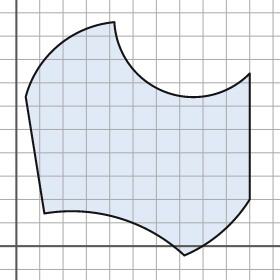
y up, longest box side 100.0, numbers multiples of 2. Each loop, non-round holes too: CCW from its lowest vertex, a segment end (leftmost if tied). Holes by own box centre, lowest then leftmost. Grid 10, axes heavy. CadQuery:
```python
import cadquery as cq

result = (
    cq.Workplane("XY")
    .moveTo(72.0, -4.0)
    .threePointArc((88.0, 6.0), (100.0, 20.0))
    .lineTo(100.0, 74.0)
    .threePointArc((64.0, 66.0), (42.0, 96.0))
    .threePointArc((18.0, 86.0), (4.0, 64.0))
    .lineTo(12.0, 14.0)
    .threePointArc((44.0, 12.0), (72.0, -4.0))
    .close()
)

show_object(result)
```